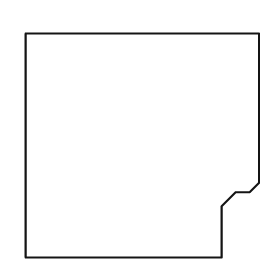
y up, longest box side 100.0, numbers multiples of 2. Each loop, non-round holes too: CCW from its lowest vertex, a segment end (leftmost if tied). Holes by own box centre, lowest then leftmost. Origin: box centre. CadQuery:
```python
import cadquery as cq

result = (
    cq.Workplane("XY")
    .moveTo(-50.0, -48.0)
    .lineTo(34.0, -48.0)
    .lineTo(34.0, -26.0)
    .lineTo(40.0, -20.0)
    .lineTo(46.0, -20.0)
    .lineTo(50.0, -16.0)
    .lineTo(50.0, 48.0)
    .lineTo(-50.0, 48.0)
    .close()
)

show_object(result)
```